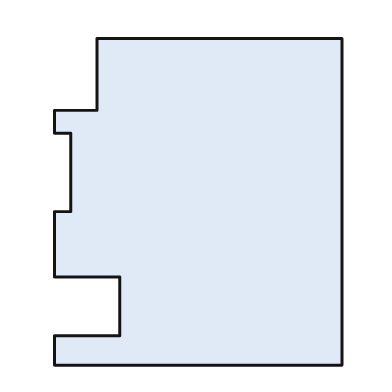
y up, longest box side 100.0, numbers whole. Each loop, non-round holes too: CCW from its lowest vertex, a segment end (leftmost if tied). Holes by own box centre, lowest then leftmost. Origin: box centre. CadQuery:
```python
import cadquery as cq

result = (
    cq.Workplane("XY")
    .moveTo(-44.0, -50.0)
    .lineTo(44.0, -50.0)
    .lineTo(44.0, 50.0)
    .lineTo(-31.0, 50.0)
    .lineTo(-31.0, 28.0)
    .lineTo(-44.0, 28.0)
    .lineTo(-44.0, 21.0)
    .lineTo(-39.0, 21.0)
    .lineTo(-39.0, -3.0)
    .lineTo(-44.0, -3.0)
    .lineTo(-44.0, -23.0)
    .lineTo(-24.0, -23.0)
    .lineTo(-24.0, -41.0)
    .lineTo(-44.0, -41.0)
    .close()
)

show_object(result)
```